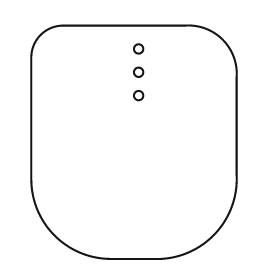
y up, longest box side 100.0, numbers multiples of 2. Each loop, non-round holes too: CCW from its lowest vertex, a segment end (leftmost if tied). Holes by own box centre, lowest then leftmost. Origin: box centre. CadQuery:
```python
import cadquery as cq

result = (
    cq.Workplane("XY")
    .moveTo(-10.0, -50.0)
    .lineTo(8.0, -50.0)
    .threePointArc((34.0, -40.0), (44.0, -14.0))
    .lineTo(44.0, 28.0)
    .threePointArc((38.0, 44.0), (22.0, 50.0))
    .lineTo(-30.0, 50.0)
    .threePointArc((-40.0, 46.0), (-44.0, 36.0))
    .lineTo(-44.0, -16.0)
    .threePointArc((-34.0, -40.0), (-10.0, -50.0))
    .close()
    .moveTo(2.0, 20.0)
    .circle(2.0)
    .moveTo(2.0, 30.0)
    .circle(2.0)
    .moveTo(2.0, 40.0)
    .circle(2.0)
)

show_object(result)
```